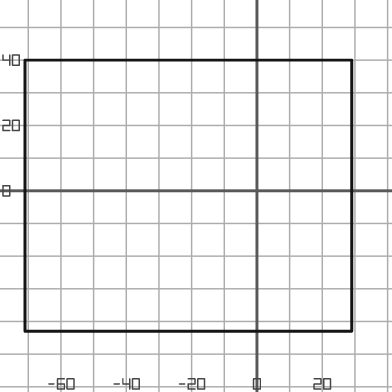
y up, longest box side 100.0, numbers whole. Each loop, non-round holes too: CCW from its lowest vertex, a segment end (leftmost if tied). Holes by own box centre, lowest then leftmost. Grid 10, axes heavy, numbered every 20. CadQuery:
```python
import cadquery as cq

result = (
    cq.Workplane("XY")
    .moveTo(-71.0, -43.0)
    .lineTo(29.0, -43.0)
    .lineTo(29.0, 40.0)
    .lineTo(-71.0, 40.0)
    .close()
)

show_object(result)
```